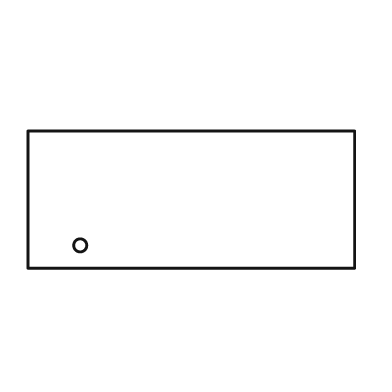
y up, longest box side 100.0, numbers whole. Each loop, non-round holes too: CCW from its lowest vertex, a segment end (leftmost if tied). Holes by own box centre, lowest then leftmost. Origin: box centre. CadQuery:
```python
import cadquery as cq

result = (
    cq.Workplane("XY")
    .moveTo(-50.0, -21.0)
    .lineTo(50.0, -21.0)
    .lineTo(50.0, 21.0)
    .lineTo(-50.0, 21.0)
    .close()
    .moveTo(-34.0, -14.0)
    .circle(2.0)
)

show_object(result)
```